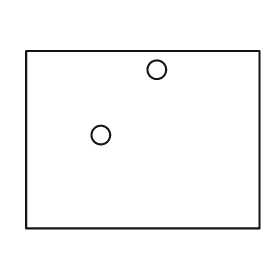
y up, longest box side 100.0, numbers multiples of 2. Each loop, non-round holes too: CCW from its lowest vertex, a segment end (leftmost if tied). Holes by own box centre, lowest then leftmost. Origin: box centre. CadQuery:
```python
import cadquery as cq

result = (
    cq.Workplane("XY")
    .moveTo(-50.0, -38.0)
    .lineTo(50.0, -38.0)
    .lineTo(50.0, 38.0)
    .lineTo(-50.0, 38.0)
    .close()
    .moveTo(-18.0, 2.0)
    .circle(4.0)
    .moveTo(6.0, 30.0)
    .circle(4.0)
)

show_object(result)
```